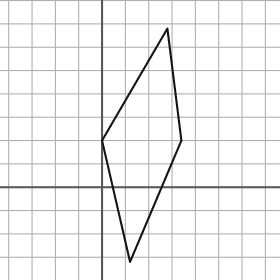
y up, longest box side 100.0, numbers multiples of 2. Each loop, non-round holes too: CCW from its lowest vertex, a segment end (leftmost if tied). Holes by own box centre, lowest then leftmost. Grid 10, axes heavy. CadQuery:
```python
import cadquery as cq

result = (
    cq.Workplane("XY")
    .moveTo(12.0, -32.0)
    .lineTo(34.0, 20.0)
    .lineTo(28.0, 68.0)
    .lineTo(0.0, 20.0)
    .close()
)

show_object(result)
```